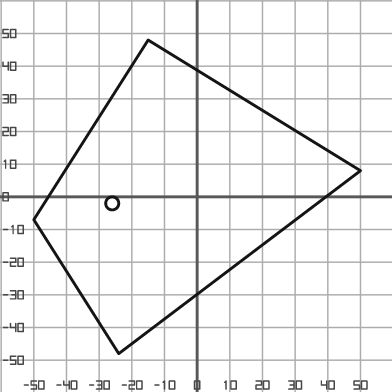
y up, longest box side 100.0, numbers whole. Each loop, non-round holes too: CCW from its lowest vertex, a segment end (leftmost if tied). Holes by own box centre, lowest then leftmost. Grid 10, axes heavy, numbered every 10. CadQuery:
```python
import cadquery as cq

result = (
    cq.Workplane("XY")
    .moveTo(-24.0, -48.0)
    .lineTo(50.0, 8.0)
    .lineTo(-15.0, 48.0)
    .lineTo(-50.0, -7.0)
    .close()
    .moveTo(-26.0, -2.0)
    .circle(2.0)
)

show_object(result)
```